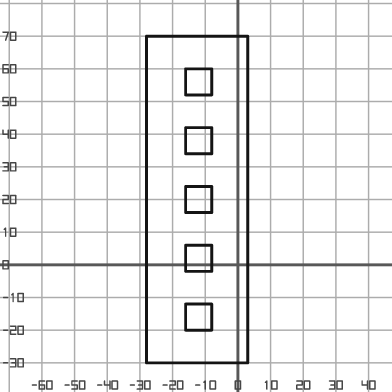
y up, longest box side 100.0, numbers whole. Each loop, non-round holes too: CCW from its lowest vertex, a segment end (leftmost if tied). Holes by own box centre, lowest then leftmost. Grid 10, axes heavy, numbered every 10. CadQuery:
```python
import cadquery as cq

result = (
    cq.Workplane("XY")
    .moveTo(-28.0, -30.0)
    .lineTo(3.0, -30.0)
    .lineTo(3.0, 70.0)
    .lineTo(-28.0, 70.0)
    .close()
    .moveTo(-16.0, -20.0)
    .lineTo(-8.0, -20.0)
    .lineTo(-8.0, -12.0)
    .lineTo(-16.0, -12.0)
    .close()
    .moveTo(-16.0, -2.0)
    .lineTo(-8.0, -2.0)
    .lineTo(-8.0, 6.0)
    .lineTo(-16.0, 6.0)
    .close()
    .moveTo(-16.0, 16.0)
    .lineTo(-8.0, 16.0)
    .lineTo(-8.0, 24.0)
    .lineTo(-16.0, 24.0)
    .close()
    .moveTo(-16.0, 34.0)
    .lineTo(-8.0, 34.0)
    .lineTo(-8.0, 42.0)
    .lineTo(-16.0, 42.0)
    .close()
    .moveTo(-16.0, 52.0)
    .lineTo(-8.0, 52.0)
    .lineTo(-8.0, 60.0)
    .lineTo(-16.0, 60.0)
    .close()
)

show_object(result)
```